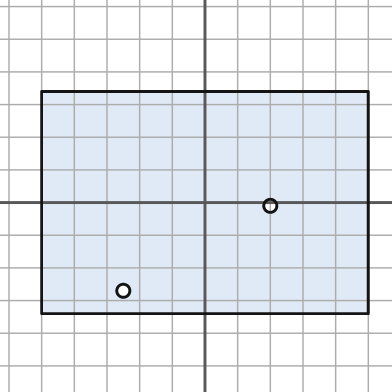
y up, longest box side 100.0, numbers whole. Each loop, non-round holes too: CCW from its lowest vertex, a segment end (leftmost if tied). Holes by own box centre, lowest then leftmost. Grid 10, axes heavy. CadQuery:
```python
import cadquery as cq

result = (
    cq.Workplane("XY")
    .moveTo(-50.0, -34.0)
    .lineTo(50.0, -34.0)
    .lineTo(50.0, 34.0)
    .lineTo(-50.0, 34.0)
    .close()
    .moveTo(-25.0, -27.0)
    .circle(2.0)
    .moveTo(20.0, -1.0)
    .circle(2.0)
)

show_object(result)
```